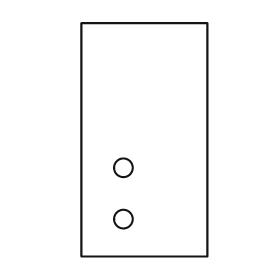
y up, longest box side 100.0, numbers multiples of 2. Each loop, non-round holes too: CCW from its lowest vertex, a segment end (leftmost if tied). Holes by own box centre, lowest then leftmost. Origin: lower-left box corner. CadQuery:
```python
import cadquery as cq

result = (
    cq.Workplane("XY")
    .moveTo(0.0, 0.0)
    .lineTo(54.0, 0.0)
    .lineTo(54.0, 100.0)
    .lineTo(0.0, 100.0)
    .close()
    .moveTo(18.0, 16.0)
    .circle(4.0)
    .moveTo(18.0, 38.0)
    .circle(4.0)
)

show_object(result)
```